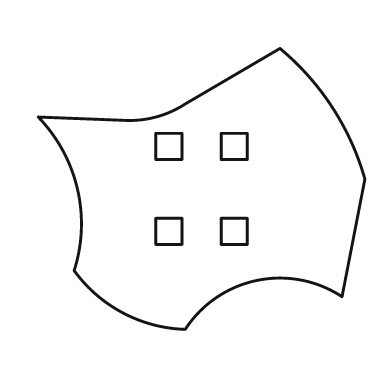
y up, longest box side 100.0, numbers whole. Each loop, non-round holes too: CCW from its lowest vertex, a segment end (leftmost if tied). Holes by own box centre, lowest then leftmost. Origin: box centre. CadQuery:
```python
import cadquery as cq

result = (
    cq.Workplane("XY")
    .moveTo(-5.0, -43.0)
    .threePointArc((17.0, -28.0), (43.0, -33.0))
    .lineTo(50.0, 3.0)
    .threePointArc((40.0, 25.0), (24.0, 43.0))
    .lineTo(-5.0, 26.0)
    .threePointArc((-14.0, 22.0), (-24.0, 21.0))
    .lineTo(-50.0, 22.0)
    .threePointArc((-38.0, 0.0), (-39.0, -25.0))
    .threePointArc((-24.0, -38.0), (-5.0, -43.0))
    .close()
    .moveTo(-14.0, -17.0)
    .lineTo(-6.0, -17.0)
    .lineTo(-6.0, -9.0)
    .lineTo(-14.0, -9.0)
    .close()
    .moveTo(6.0, -17.0)
    .lineTo(14.0, -17.0)
    .lineTo(14.0, -9.0)
    .lineTo(6.0, -9.0)
    .close()
    .moveTo(-14.0, 9.0)
    .lineTo(-6.0, 9.0)
    .lineTo(-6.0, 17.0)
    .lineTo(-14.0, 17.0)
    .close()
    .moveTo(6.0, 9.0)
    .lineTo(14.0, 9.0)
    .lineTo(14.0, 17.0)
    .lineTo(6.0, 17.0)
    .close()
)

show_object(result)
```